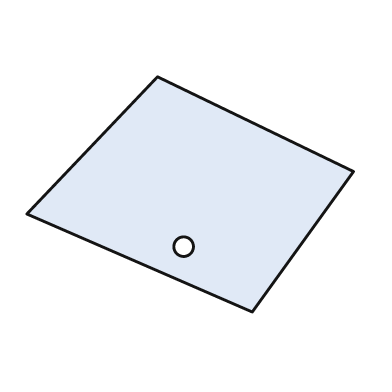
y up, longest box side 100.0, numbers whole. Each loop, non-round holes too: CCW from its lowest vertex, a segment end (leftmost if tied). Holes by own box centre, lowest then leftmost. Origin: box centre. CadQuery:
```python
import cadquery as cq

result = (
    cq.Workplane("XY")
    .moveTo(19.0, -36.0)
    .lineTo(50.0, 7.0)
    .lineTo(-10.0, 36.0)
    .lineTo(-50.0, -6.0)
    .close()
    .moveTo(-2.0, -16.0)
    .circle(3.0)
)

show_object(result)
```